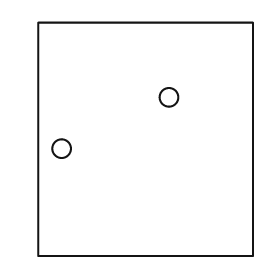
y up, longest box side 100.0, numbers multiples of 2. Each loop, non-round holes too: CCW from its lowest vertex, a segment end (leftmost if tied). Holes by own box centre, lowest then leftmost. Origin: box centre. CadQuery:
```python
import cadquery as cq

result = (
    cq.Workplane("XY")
    .moveTo(-46.0, -50.0)
    .lineTo(46.0, -50.0)
    .lineTo(46.0, 50.0)
    .lineTo(-46.0, 50.0)
    .close()
    .moveTo(-36.0, -4.0)
    .circle(4.0)
    .moveTo(10.0, 18.0)
    .circle(4.0)
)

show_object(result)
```